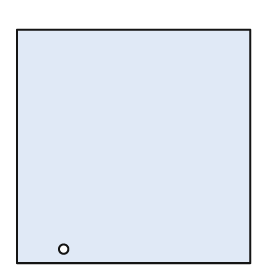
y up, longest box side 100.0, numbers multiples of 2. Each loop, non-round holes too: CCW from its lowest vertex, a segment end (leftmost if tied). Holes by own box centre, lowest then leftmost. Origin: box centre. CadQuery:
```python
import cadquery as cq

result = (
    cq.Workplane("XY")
    .moveTo(-50.0, -50.0)
    .lineTo(50.0, -50.0)
    .lineTo(50.0, 50.0)
    .lineTo(-50.0, 50.0)
    .close()
    .moveTo(-30.0, -44.0)
    .circle(2.0)
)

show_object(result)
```